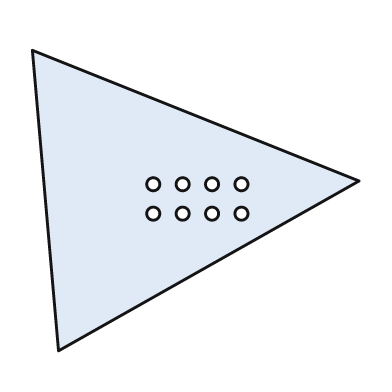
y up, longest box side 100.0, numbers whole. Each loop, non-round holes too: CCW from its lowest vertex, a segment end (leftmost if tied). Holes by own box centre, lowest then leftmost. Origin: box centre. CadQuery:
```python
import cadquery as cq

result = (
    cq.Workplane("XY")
    .moveTo(-42.0, -46.0)
    .lineTo(50.0, 6.0)
    .lineTo(-50.0, 46.0)
    .close()
    .moveTo(-13.0, -4.0)
    .circle(2.0)
    .moveTo(-4.0, -4.0)
    .circle(2.0)
    .moveTo(5.0, -4.0)
    .circle(2.0)
    .moveTo(14.0, -4.0)
    .circle(2.0)
    .moveTo(-13.0, 5.0)
    .circle(2.0)
    .moveTo(-4.0, 5.0)
    .circle(2.0)
    .moveTo(5.0, 5.0)
    .circle(2.0)
    .moveTo(14.0, 5.0)
    .circle(2.0)
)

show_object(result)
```